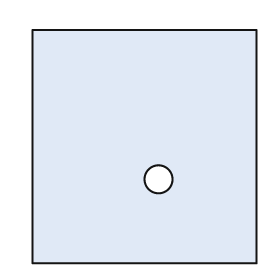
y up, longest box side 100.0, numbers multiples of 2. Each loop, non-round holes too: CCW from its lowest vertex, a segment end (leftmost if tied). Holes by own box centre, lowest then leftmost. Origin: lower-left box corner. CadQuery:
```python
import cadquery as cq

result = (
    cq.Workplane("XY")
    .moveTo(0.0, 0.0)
    .lineTo(96.0, 0.0)
    .lineTo(96.0, 100.0)
    .lineTo(0.0, 100.0)
    .close()
    .moveTo(54.0, 36.0)
    .circle(6.0)
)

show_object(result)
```